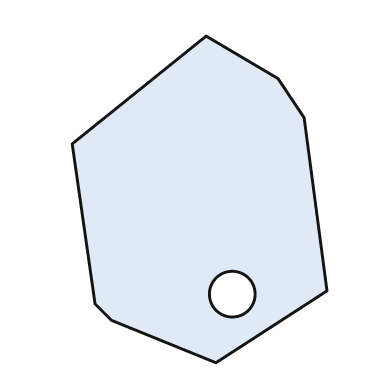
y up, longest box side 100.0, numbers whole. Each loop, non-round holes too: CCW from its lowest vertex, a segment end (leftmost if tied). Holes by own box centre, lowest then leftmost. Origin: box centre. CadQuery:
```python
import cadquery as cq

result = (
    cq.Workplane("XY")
    .moveTo(5.0, -50.0)
    .lineTo(39.0, -28.0)
    .lineTo(32.0, 25.0)
    .lineTo(24.0, 37.0)
    .lineTo(2.0, 50.0)
    .lineTo(-39.0, 17.0)
    .lineTo(-32.0, -32.0)
    .lineTo(-27.0, -37.0)
    .close()
    .moveTo(10.0, -29.0)
    .circle(7.0)
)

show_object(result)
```